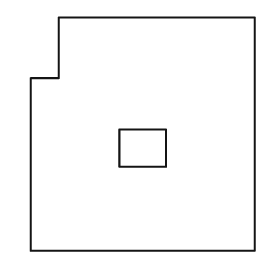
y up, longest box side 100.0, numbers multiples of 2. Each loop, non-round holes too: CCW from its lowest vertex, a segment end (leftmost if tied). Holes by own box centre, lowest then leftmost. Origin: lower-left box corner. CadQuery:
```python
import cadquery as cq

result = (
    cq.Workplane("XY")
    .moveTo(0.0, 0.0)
    .lineTo(96.0, 0.0)
    .lineTo(96.0, 100.0)
    .lineTo(12.0, 100.0)
    .lineTo(12.0, 74.0)
    .lineTo(0.0, 74.0)
    .close()
    .moveTo(38.0, 36.0)
    .lineTo(58.0, 36.0)
    .lineTo(58.0, 52.0)
    .lineTo(38.0, 52.0)
    .close()
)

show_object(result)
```